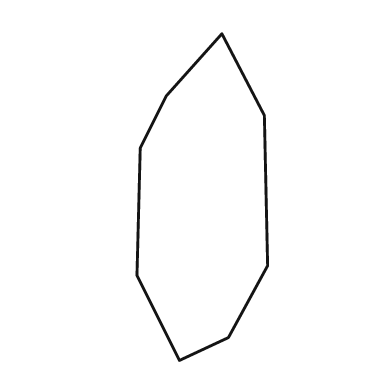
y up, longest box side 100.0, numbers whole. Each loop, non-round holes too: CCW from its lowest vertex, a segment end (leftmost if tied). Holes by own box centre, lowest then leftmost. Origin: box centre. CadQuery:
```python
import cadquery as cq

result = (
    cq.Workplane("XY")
    .moveTo(-7.0, -50.0)
    .lineTo(8.0, -43.0)
    .lineTo(20.0, -21.0)
    .lineTo(19.0, 25.0)
    .lineTo(6.0, 50.0)
    .lineTo(-11.0, 31.0)
    .lineTo(-19.0, 15.0)
    .lineTo(-20.0, -24.0)
    .close()
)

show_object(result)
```